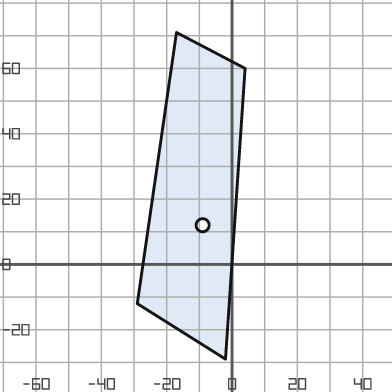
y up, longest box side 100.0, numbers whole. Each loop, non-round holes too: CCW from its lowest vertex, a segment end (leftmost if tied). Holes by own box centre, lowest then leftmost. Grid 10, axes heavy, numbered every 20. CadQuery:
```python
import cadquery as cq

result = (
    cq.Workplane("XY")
    .moveTo(-2.0, -29.0)
    .lineTo(4.0, 60.0)
    .lineTo(-17.0, 71.0)
    .lineTo(-29.0, -12.0)
    .close()
    .moveTo(-9.0, 12.0)
    .circle(2.0)
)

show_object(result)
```